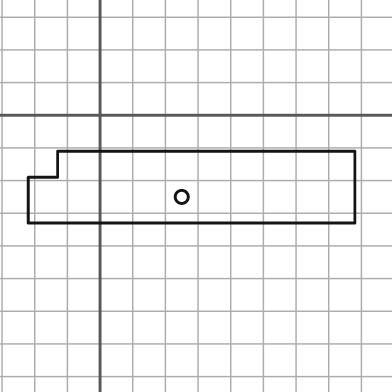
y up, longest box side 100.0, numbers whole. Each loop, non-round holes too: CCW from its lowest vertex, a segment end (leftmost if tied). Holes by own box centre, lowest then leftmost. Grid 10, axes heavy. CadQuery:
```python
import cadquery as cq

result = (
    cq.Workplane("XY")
    .moveTo(-22.0, -33.0)
    .lineTo(78.0, -33.0)
    .lineTo(78.0, -11.0)
    .lineTo(-13.0, -11.0)
    .lineTo(-13.0, -19.0)
    .lineTo(-22.0, -19.0)
    .close()
    .moveTo(25.0, -25.0)
    .circle(2.0)
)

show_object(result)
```